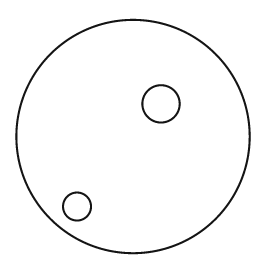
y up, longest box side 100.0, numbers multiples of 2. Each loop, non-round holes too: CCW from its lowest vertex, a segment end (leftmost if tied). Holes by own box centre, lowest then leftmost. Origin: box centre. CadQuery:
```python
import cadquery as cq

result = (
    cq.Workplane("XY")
    .moveTo(0.0, 0.0)
    .circle(50.0)
    .moveTo(-24.0, -30.0)
    .circle(6.0)
    .moveTo(12.0, 14.0)
    .circle(8.0)
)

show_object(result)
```